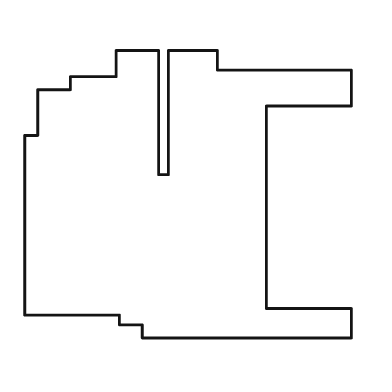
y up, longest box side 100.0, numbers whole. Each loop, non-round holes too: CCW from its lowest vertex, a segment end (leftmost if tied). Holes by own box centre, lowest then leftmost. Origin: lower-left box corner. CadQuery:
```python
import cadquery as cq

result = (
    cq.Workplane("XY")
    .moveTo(36.0, 0.0)
    .lineTo(100.0, 0.0)
    .lineTo(100.0, 9.0)
    .lineTo(74.0, 9.0)
    .lineTo(74.0, 71.0)
    .lineTo(100.0, 71.0)
    .lineTo(100.0, 82.0)
    .lineTo(59.0, 82.0)
    .lineTo(59.0, 88.0)
    .lineTo(44.0, 88.0)
    .lineTo(44.0, 50.0)
    .lineTo(41.0, 50.0)
    .lineTo(41.0, 88.0)
    .lineTo(28.0, 88.0)
    .lineTo(28.0, 80.0)
    .lineTo(14.0, 80.0)
    .lineTo(14.0, 76.0)
    .lineTo(4.0, 76.0)
    .lineTo(4.0, 62.0)
    .lineTo(0.0, 62.0)
    .lineTo(0.0, 7.0)
    .lineTo(29.0, 7.0)
    .lineTo(29.0, 4.0)
    .lineTo(36.0, 4.0)
    .close()
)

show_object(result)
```